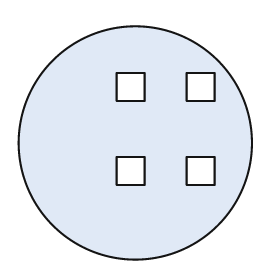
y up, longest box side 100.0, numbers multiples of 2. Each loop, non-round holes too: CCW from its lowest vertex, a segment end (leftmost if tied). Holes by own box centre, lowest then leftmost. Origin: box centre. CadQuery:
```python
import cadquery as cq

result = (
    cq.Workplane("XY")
    .moveTo(0.0, 0.0)
    .circle(50.0)
    .moveTo(-8.0, -18.0)
    .lineTo(4.0, -18.0)
    .lineTo(4.0, -6.0)
    .lineTo(-8.0, -6.0)
    .close()
    .moveTo(22.0, -18.0)
    .lineTo(34.0, -18.0)
    .lineTo(34.0, -6.0)
    .lineTo(22.0, -6.0)
    .close()
    .moveTo(-8.0, 18.0)
    .lineTo(4.0, 18.0)
    .lineTo(4.0, 30.0)
    .lineTo(-8.0, 30.0)
    .close()
    .moveTo(22.0, 18.0)
    .lineTo(34.0, 18.0)
    .lineTo(34.0, 30.0)
    .lineTo(22.0, 30.0)
    .close()
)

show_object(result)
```